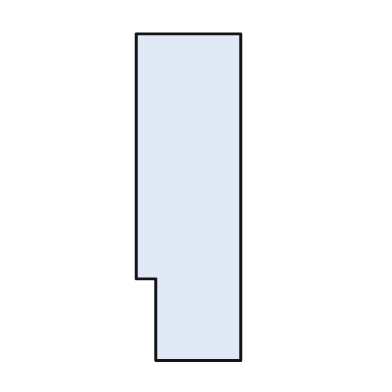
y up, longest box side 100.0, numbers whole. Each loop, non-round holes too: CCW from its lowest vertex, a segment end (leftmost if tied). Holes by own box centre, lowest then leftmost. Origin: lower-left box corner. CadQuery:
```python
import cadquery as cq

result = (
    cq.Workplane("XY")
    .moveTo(6.0, 0.0)
    .lineTo(32.0, 0.0)
    .lineTo(32.0, 100.0)
    .lineTo(0.0, 100.0)
    .lineTo(0.0, 25.0)
    .lineTo(6.0, 25.0)
    .close()
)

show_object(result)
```